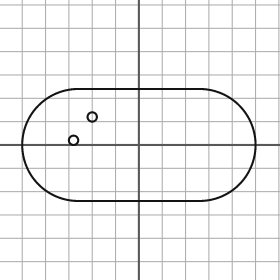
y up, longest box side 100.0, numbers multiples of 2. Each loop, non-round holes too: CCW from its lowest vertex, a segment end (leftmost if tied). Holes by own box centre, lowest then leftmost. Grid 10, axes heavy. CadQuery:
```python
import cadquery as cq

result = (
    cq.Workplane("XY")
    .moveTo(-26.0, -24.0)
    .lineTo(26.0, -24.0)
    .threePointArc((50.0, 0.0), (26.0, 24.0))
    .lineTo(-26.0, 24.0)
    .threePointArc((-50.0, 0.0), (-26.0, -24.0))
    .close()
    .moveTo(-28.0, 2.0)
    .circle(2.0)
    .moveTo(-20.0, 12.0)
    .circle(2.0)
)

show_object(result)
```